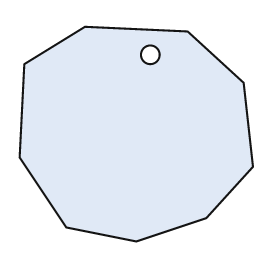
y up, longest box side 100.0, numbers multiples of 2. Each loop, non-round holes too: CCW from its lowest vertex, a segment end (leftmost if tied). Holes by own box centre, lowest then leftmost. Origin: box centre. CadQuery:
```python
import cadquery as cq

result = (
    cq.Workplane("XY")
    .moveTo(0.0, -46.0)
    .lineTo(30.0, -36.0)
    .lineTo(50.0, -14.0)
    .lineTo(46.0, 22.0)
    .lineTo(22.0, 44.0)
    .lineTo(-22.0, 46.0)
    .lineTo(-48.0, 30.0)
    .lineTo(-50.0, -10.0)
    .lineTo(-30.0, -40.0)
    .close()
    .moveTo(6.0, 34.0)
    .circle(4.0)
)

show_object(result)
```